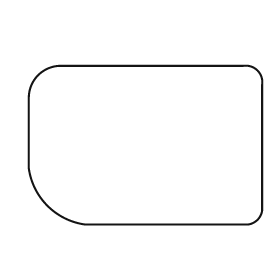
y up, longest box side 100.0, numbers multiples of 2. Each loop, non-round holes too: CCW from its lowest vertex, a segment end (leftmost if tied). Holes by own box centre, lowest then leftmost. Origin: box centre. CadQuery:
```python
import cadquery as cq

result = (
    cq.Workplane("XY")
    .moveTo(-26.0, -34.0)
    .lineTo(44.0, -34.0)
    .threePointArc((48.0, -32.0), (50.0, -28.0))
    .lineTo(50.0, 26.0)
    .threePointArc((48.0, 32.0), (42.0, 34.0))
    .lineTo(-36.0, 34.0)
    .threePointArc((-46.0, 30.0), (-50.0, 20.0))
    .lineTo(-50.0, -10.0)
    .threePointArc((-42.0, -26.0), (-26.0, -34.0))
    .close()
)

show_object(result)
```